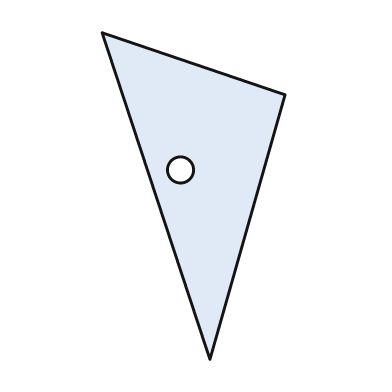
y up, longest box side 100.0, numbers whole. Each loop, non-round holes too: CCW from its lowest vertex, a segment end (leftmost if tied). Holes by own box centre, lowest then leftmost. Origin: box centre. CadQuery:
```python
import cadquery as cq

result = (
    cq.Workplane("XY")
    .moveTo(5.0, -50.0)
    .lineTo(28.0, 31.0)
    .lineTo(-28.0, 50.0)
    .close()
    .moveTo(-4.0, 8.0)
    .circle(4.0)
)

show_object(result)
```